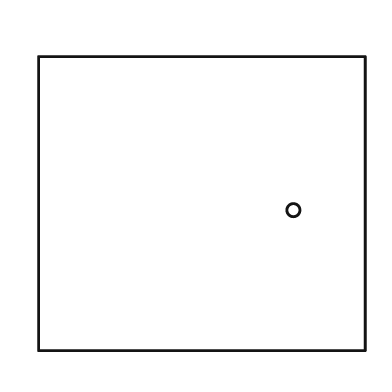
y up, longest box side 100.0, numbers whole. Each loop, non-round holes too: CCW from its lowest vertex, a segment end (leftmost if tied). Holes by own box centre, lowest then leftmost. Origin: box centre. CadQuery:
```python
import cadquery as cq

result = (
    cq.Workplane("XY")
    .moveTo(-50.0, -45.0)
    .lineTo(50.0, -45.0)
    .lineTo(50.0, 45.0)
    .lineTo(-50.0, 45.0)
    .close()
    .moveTo(28.0, -2.0)
    .circle(2.0)
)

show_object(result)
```